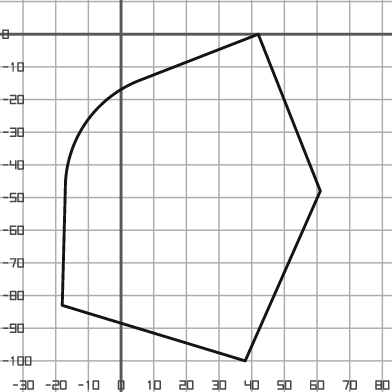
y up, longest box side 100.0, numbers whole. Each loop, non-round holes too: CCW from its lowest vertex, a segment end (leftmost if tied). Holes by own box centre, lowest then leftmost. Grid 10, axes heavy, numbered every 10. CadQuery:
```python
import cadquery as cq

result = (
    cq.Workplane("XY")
    .moveTo(38.0, -100.0)
    .lineTo(61.0, -48.0)
    .lineTo(42.0, 0.0)
    .lineTo(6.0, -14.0)
    .threePointArc((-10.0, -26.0), (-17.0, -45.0))
    .lineTo(-18.0, -83.0)
    .close()
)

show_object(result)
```